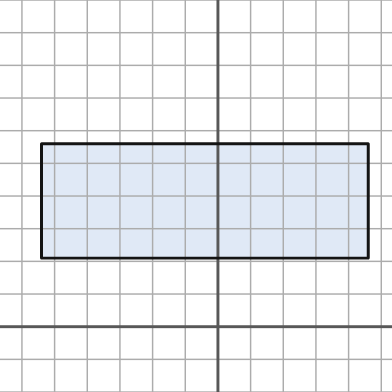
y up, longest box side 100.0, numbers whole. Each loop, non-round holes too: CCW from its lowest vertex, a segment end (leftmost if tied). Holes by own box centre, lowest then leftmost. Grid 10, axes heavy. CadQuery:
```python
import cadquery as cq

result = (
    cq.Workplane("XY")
    .moveTo(-54.0, 21.0)
    .lineTo(46.0, 21.0)
    .lineTo(46.0, 56.0)
    .lineTo(-54.0, 56.0)
    .close()
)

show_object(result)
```